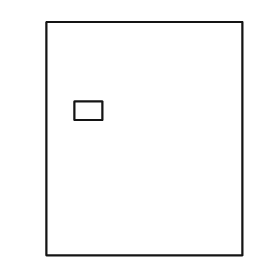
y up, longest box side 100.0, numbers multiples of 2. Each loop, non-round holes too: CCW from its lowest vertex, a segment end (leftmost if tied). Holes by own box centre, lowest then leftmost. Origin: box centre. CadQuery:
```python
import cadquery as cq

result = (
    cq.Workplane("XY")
    .moveTo(-42.0, -50.0)
    .lineTo(42.0, -50.0)
    .lineTo(42.0, 50.0)
    .lineTo(-42.0, 50.0)
    .close()
    .moveTo(-30.0, 8.0)
    .lineTo(-18.0, 8.0)
    .lineTo(-18.0, 16.0)
    .lineTo(-30.0, 16.0)
    .close()
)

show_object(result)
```